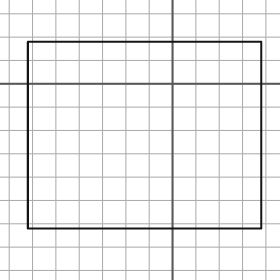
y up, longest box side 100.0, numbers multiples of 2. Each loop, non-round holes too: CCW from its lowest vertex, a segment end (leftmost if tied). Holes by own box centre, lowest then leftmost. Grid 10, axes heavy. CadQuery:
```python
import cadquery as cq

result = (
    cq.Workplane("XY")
    .moveTo(-62.0, -62.0)
    .lineTo(38.0, -62.0)
    .lineTo(38.0, 18.0)
    .lineTo(-62.0, 18.0)
    .close()
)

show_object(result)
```